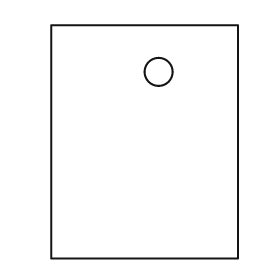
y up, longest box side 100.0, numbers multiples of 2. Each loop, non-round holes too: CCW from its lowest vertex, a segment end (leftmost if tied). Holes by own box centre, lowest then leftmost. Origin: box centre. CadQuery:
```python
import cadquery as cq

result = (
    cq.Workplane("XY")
    .moveTo(-40.0, -50.0)
    .lineTo(40.0, -50.0)
    .lineTo(40.0, 50.0)
    .lineTo(-40.0, 50.0)
    .close()
    .moveTo(6.0, 30.0)
    .circle(6.0)
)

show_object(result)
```